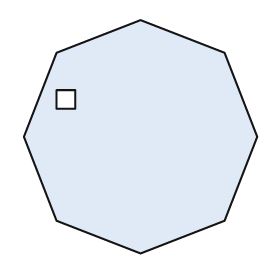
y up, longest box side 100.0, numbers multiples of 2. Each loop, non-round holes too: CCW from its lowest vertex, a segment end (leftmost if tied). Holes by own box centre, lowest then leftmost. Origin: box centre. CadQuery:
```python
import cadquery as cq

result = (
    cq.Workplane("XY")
    .moveTo(0.0, -50.0)
    .lineTo(36.0, -36.0)
    .lineTo(50.0, 0.0)
    .lineTo(36.0, 36.0)
    .lineTo(0.0, 50.0)
    .lineTo(-36.0, 36.0)
    .lineTo(-50.0, 0.0)
    .lineTo(-36.0, -36.0)
    .close()
    .moveTo(-36.0, 12.0)
    .lineTo(-28.0, 12.0)
    .lineTo(-28.0, 20.0)
    .lineTo(-36.0, 20.0)
    .close()
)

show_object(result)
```